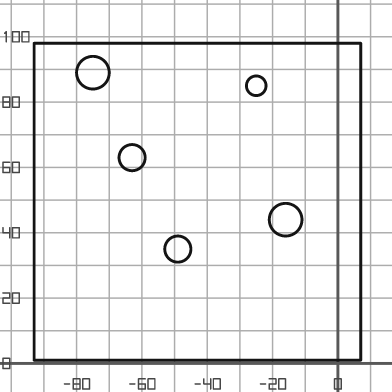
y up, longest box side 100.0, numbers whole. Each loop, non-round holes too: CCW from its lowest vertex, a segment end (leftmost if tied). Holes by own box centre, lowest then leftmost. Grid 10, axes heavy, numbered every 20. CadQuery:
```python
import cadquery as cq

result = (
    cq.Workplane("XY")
    .moveTo(-93.0, 1.0)
    .lineTo(7.0, 1.0)
    .lineTo(7.0, 98.0)
    .lineTo(-93.0, 98.0)
    .close()
    .moveTo(-49.0, 35.0)
    .circle(4.0)
    .moveTo(-16.0, 44.0)
    .circle(5.0)
    .moveTo(-63.0, 63.0)
    .circle(4.0)
    .moveTo(-25.0, 85.0)
    .circle(3.0)
    .moveTo(-75.0, 89.0)
    .circle(5.0)
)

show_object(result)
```